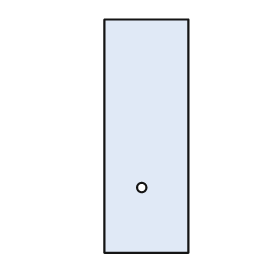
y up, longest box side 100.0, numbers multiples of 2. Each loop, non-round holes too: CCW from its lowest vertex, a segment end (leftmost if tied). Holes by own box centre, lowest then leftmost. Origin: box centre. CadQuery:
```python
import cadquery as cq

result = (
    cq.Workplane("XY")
    .moveTo(-18.0, -50.0)
    .lineTo(18.0, -50.0)
    .lineTo(18.0, 50.0)
    .lineTo(-18.0, 50.0)
    .close()
    .moveTo(-2.0, -22.0)
    .circle(2.0)
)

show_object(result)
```